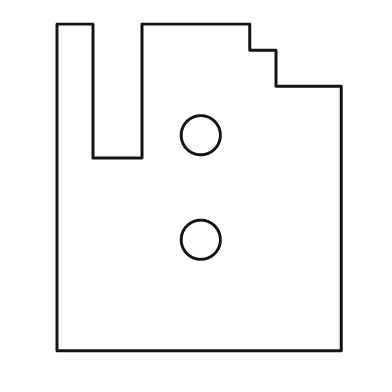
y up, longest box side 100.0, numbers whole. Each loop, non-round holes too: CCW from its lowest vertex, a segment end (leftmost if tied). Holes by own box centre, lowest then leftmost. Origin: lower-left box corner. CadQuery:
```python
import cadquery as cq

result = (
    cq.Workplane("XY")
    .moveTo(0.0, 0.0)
    .lineTo(87.0, 0.0)
    .lineTo(87.0, 81.0)
    .lineTo(67.0, 81.0)
    .lineTo(67.0, 92.0)
    .lineTo(59.0, 92.0)
    .lineTo(59.0, 100.0)
    .lineTo(26.0, 100.0)
    .lineTo(26.0, 59.0)
    .lineTo(11.0, 59.0)
    .lineTo(11.0, 100.0)
    .lineTo(0.0, 100.0)
    .close()
    .moveTo(44.0, 34.0)
    .circle(6.0)
    .moveTo(44.0, 66.0)
    .circle(6.0)
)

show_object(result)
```